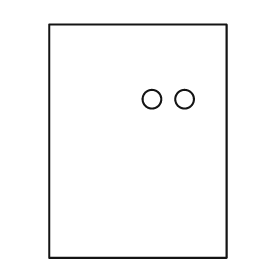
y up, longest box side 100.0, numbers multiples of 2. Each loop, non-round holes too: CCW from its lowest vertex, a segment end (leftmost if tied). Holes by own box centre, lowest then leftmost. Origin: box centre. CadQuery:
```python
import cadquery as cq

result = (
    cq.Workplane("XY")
    .moveTo(-38.0, -50.0)
    .lineTo(38.0, -50.0)
    .lineTo(38.0, 50.0)
    .lineTo(-38.0, 50.0)
    .close()
    .moveTo(6.0, 18.0)
    .circle(4.0)
    .moveTo(20.0, 18.0)
    .circle(4.0)
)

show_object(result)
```